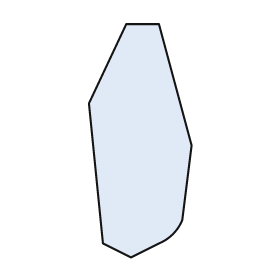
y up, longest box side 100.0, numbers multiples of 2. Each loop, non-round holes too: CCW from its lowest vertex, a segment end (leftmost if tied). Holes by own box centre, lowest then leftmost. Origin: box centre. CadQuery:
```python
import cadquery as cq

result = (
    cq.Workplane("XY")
    .moveTo(-4.0, -50.0)
    .lineTo(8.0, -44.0)
    .threePointArc((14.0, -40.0), (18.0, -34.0))
    .lineTo(22.0, -2.0)
    .lineTo(8.0, 50.0)
    .lineTo(-6.0, 50.0)
    .lineTo(-22.0, 16.0)
    .lineTo(-16.0, -44.0)
    .close()
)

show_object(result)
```